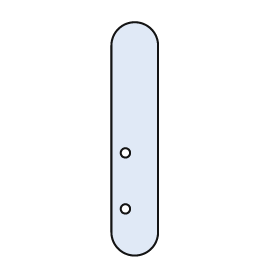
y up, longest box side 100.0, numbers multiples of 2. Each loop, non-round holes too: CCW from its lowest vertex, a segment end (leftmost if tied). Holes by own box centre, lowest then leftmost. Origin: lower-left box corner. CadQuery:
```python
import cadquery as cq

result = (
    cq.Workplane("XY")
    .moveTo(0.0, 10.0)
    .threePointArc((10.0, 0.0), (20.0, 10.0))
    .lineTo(20.0, 90.0)
    .threePointArc((10.0, 100.0), (0.0, 90.0))
    .close()
    .moveTo(6.0, 20.0)
    .circle(2.0)
    .moveTo(6.0, 44.0)
    .circle(2.0)
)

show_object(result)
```